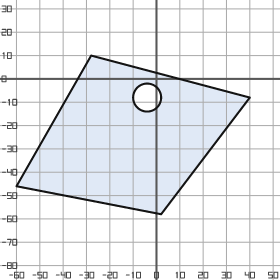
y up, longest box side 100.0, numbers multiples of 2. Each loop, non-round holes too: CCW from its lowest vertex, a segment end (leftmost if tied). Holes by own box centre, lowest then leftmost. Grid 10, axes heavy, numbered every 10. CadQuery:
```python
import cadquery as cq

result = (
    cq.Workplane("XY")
    .moveTo(2.0, -58.0)
    .lineTo(40.0, -8.0)
    .lineTo(-28.0, 10.0)
    .lineTo(-60.0, -46.0)
    .close()
    .moveTo(-4.0, -8.0)
    .circle(6.0)
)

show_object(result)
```